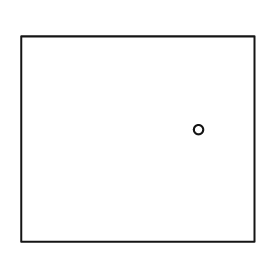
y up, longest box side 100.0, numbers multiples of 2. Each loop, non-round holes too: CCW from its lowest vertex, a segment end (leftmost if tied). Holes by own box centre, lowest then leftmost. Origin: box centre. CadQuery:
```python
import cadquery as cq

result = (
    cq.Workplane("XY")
    .moveTo(-50.0, -44.0)
    .lineTo(50.0, -44.0)
    .lineTo(50.0, 44.0)
    .lineTo(-50.0, 44.0)
    .close()
    .moveTo(26.0, 4.0)
    .circle(2.0)
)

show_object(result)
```